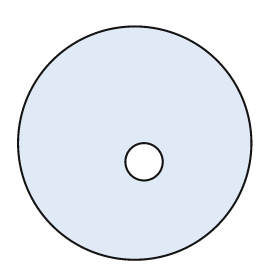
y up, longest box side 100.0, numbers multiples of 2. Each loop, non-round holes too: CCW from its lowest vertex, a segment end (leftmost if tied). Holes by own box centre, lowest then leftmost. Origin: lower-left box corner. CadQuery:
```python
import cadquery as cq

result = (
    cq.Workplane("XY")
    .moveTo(50.0, 50.0)
    .circle(50.0)
    .moveTo(54.0, 42.0)
    .circle(8.0)
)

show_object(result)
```